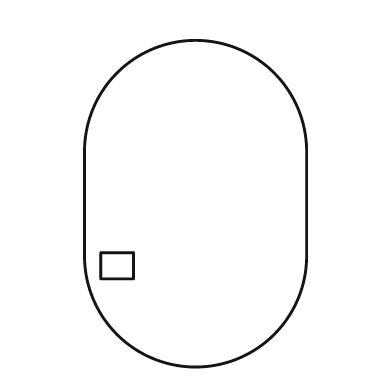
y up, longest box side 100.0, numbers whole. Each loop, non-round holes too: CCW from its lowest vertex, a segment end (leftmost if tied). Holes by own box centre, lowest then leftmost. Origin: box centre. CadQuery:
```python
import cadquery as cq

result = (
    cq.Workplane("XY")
    .moveTo(-34.0, -16.0)
    .threePointArc((0.0, -50.0), (34.0, -16.0))
    .lineTo(34.0, 16.0)
    .threePointArc((0.0, 50.0), (-34.0, 16.0))
    .close()
    .moveTo(-29.0, -23.0)
    .lineTo(-19.0, -23.0)
    .lineTo(-19.0, -15.0)
    .lineTo(-29.0, -15.0)
    .close()
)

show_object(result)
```